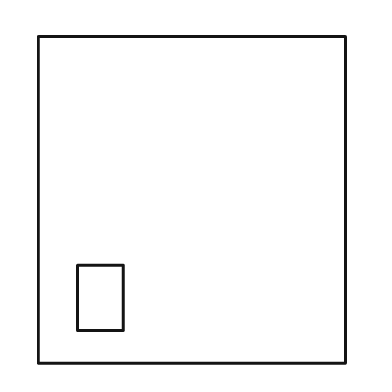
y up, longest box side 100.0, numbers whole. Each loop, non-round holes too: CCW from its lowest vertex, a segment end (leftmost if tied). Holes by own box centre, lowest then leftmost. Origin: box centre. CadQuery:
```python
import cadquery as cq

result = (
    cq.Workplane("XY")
    .moveTo(-47.0, -50.0)
    .lineTo(47.0, -50.0)
    .lineTo(47.0, 50.0)
    .lineTo(-47.0, 50.0)
    .close()
    .moveTo(-35.0, -40.0)
    .lineTo(-21.0, -40.0)
    .lineTo(-21.0, -20.0)
    .lineTo(-35.0, -20.0)
    .close()
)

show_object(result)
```